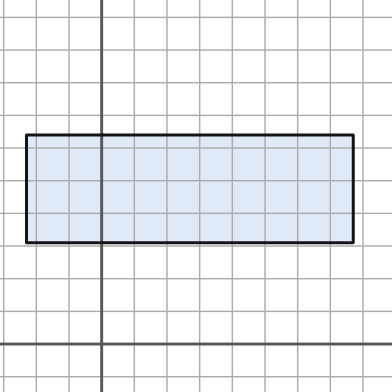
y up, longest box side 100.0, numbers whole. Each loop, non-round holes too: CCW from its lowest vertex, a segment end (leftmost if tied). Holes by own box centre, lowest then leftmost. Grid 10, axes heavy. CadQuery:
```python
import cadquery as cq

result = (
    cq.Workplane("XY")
    .moveTo(-23.0, 31.0)
    .lineTo(77.0, 31.0)
    .lineTo(77.0, 64.0)
    .lineTo(-23.0, 64.0)
    .close()
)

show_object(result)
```